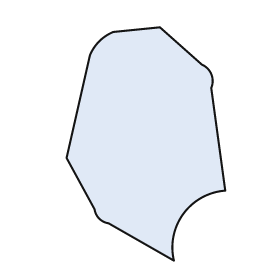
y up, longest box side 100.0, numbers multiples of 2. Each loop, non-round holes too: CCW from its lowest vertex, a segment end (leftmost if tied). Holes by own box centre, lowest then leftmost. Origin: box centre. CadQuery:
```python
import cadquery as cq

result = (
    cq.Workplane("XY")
    .moveTo(12.0, -50.0)
    .threePointArc((16.0, -30.0), (34.0, -20.0))
    .lineTo(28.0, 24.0)
    .threePointArc((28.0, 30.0), (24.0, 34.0))
    .lineTo(6.0, 50.0)
    .lineTo(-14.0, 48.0)
    .threePointArc((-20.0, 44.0), (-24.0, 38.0))
    .lineTo(-34.0, -6.0)
    .lineTo(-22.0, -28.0)
    .threePointArc((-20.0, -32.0), (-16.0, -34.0))
    .close()
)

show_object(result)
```